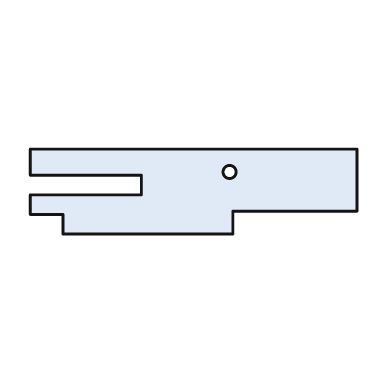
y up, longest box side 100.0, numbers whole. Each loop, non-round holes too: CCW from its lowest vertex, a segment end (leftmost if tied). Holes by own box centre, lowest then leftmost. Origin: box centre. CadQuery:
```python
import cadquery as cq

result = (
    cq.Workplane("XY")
    .moveTo(-40.0, -13.0)
    .lineTo(12.0, -13.0)
    .lineTo(12.0, -6.0)
    .lineTo(50.0, -6.0)
    .lineTo(50.0, 13.0)
    .lineTo(-50.0, 13.0)
    .lineTo(-50.0, 5.0)
    .lineTo(-16.0, 5.0)
    .lineTo(-16.0, -1.0)
    .lineTo(-50.0, -1.0)
    .lineTo(-50.0, -7.0)
    .lineTo(-40.0, -7.0)
    .close()
    .moveTo(11.0, 6.0)
    .circle(2.0)
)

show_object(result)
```